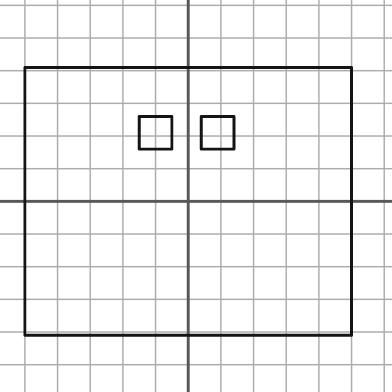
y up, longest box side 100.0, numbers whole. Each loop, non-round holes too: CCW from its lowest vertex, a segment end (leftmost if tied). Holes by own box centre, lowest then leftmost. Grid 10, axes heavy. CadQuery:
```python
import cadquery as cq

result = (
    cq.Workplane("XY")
    .moveTo(-50.0, -41.0)
    .lineTo(50.0, -41.0)
    .lineTo(50.0, 41.0)
    .lineTo(-50.0, 41.0)
    .close()
    .moveTo(-15.0, 16.0)
    .lineTo(-5.0, 16.0)
    .lineTo(-5.0, 26.0)
    .lineTo(-15.0, 26.0)
    .close()
    .moveTo(4.0, 16.0)
    .lineTo(14.0, 16.0)
    .lineTo(14.0, 26.0)
    .lineTo(4.0, 26.0)
    .close()
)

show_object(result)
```